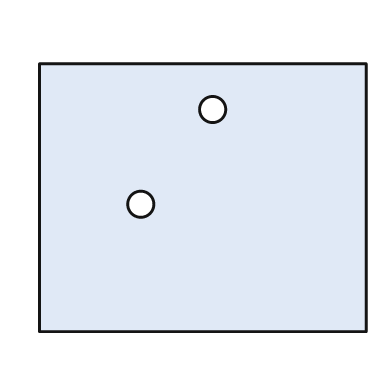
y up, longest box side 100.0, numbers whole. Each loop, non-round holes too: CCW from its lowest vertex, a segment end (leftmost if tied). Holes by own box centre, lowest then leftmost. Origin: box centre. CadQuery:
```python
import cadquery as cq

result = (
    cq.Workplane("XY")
    .moveTo(-50.0, -41.0)
    .lineTo(50.0, -41.0)
    .lineTo(50.0, 41.0)
    .lineTo(-50.0, 41.0)
    .close()
    .moveTo(-19.0, -2.0)
    .circle(4.0)
    .moveTo(3.0, 27.0)
    .circle(4.0)
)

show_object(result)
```